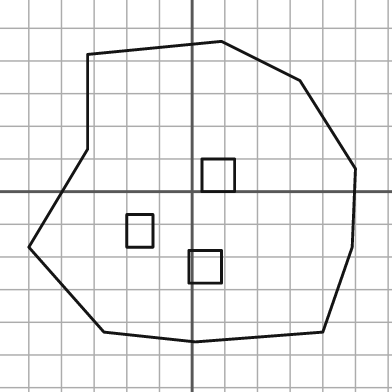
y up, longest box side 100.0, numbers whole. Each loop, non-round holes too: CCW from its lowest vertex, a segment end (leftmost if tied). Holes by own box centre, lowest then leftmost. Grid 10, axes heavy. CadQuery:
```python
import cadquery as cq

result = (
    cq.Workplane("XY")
    .moveTo(1.0, -46.0)
    .lineTo(40.0, -43.0)
    .lineTo(49.0, -17.0)
    .lineTo(50.0, 7.0)
    .lineTo(33.0, 34.0)
    .lineTo(9.0, 46.0)
    .lineTo(-32.0, 42.0)
    .lineTo(-32.0, 13.0)
    .lineTo(-50.0, -17.0)
    .lineTo(-27.0, -43.0)
    .close()
    .moveTo(-1.0, -28.0)
    .lineTo(9.0, -28.0)
    .lineTo(9.0, -18.0)
    .lineTo(-1.0, -18.0)
    .close()
    .moveTo(-20.0, -17.0)
    .lineTo(-12.0, -17.0)
    .lineTo(-12.0, -7.0)
    .lineTo(-20.0, -7.0)
    .close()
    .moveTo(3.0, 0.0)
    .lineTo(13.0, 0.0)
    .lineTo(13.0, 10.0)
    .lineTo(3.0, 10.0)
    .close()
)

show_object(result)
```